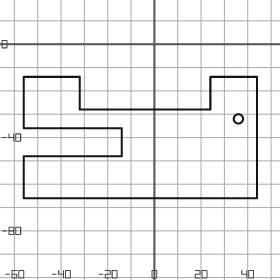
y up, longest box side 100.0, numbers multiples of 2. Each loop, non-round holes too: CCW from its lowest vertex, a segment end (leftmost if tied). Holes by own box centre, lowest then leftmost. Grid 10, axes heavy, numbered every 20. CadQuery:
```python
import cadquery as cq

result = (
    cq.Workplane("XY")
    .moveTo(-56.0, -66.0)
    .lineTo(44.0, -66.0)
    .lineTo(44.0, -14.0)
    .lineTo(24.0, -14.0)
    .lineTo(24.0, -28.0)
    .lineTo(-32.0, -28.0)
    .lineTo(-32.0, -14.0)
    .lineTo(-56.0, -14.0)
    .lineTo(-56.0, -36.0)
    .lineTo(-14.0, -36.0)
    .lineTo(-14.0, -48.0)
    .lineTo(-56.0, -48.0)
    .close()
    .moveTo(36.0, -32.0)
    .circle(2.0)
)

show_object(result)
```